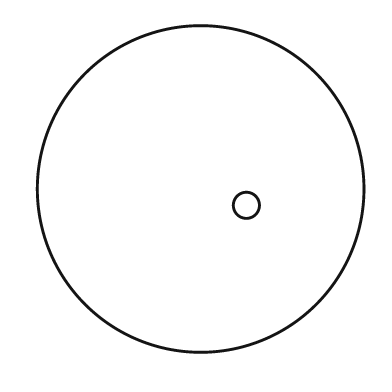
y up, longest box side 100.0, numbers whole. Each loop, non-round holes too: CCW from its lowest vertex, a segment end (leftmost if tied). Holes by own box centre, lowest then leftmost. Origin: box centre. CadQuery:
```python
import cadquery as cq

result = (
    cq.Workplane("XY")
    .moveTo(0.0, 0.0)
    .circle(50.0)
    .moveTo(14.0, -5.0)
    .circle(4.0)
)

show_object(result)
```